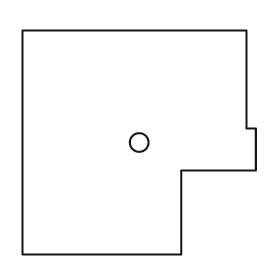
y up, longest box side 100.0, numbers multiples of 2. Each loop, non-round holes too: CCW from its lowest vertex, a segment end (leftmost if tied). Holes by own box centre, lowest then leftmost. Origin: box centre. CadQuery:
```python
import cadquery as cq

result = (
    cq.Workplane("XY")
    .moveTo(-50.0, -48.0)
    .lineTo(18.0, -48.0)
    .lineTo(18.0, -12.0)
    .lineTo(50.0, -12.0)
    .lineTo(50.0, 6.0)
    .lineTo(46.0, 6.0)
    .lineTo(46.0, 48.0)
    .lineTo(-50.0, 48.0)
    .close()
    .moveTo(0.0, 0.0)
    .circle(4.0)
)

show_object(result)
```